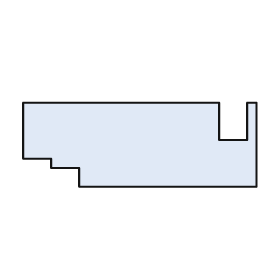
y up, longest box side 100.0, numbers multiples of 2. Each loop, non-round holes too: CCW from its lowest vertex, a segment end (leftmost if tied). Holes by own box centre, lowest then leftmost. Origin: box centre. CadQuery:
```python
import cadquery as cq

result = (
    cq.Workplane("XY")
    .moveTo(-26.0, -18.0)
    .lineTo(50.0, -18.0)
    .lineTo(50.0, 18.0)
    .lineTo(46.0, 18.0)
    .lineTo(46.0, 2.0)
    .lineTo(34.0, 2.0)
    .lineTo(34.0, 18.0)
    .lineTo(-50.0, 18.0)
    .lineTo(-50.0, -6.0)
    .lineTo(-38.0, -6.0)
    .lineTo(-38.0, -10.0)
    .lineTo(-26.0, -10.0)
    .close()
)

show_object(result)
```